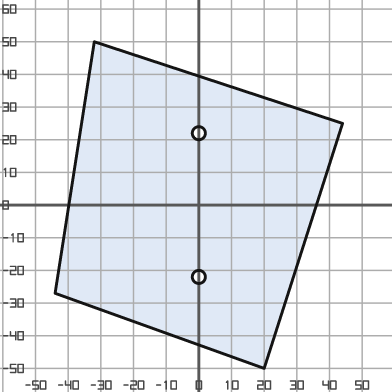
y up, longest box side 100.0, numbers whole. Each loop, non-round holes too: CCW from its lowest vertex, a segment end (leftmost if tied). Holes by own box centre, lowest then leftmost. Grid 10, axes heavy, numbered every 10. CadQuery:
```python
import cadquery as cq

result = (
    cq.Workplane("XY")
    .moveTo(20.0, -50.0)
    .lineTo(44.0, 25.0)
    .lineTo(-32.0, 50.0)
    .lineTo(-44.0, -27.0)
    .close()
    .moveTo(0.0, -22.0)
    .circle(2.0)
    .moveTo(0.0, 22.0)
    .circle(2.0)
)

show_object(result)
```